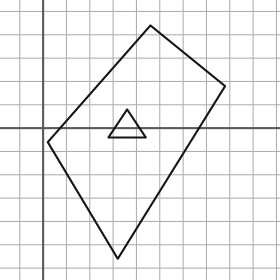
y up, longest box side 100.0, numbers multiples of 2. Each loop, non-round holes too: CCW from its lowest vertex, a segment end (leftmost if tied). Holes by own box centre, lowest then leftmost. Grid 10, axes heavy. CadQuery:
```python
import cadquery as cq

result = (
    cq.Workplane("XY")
    .moveTo(32.0, -56.0)
    .lineTo(78.0, 18.0)
    .lineTo(46.0, 44.0)
    .lineTo(2.0, -6.0)
    .close()
    .moveTo(28.0, -4.0)
    .lineTo(44.0, -4.0)
    .lineTo(36.0, 8.0)
    .close()
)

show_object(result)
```